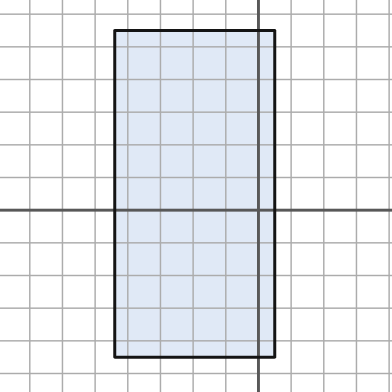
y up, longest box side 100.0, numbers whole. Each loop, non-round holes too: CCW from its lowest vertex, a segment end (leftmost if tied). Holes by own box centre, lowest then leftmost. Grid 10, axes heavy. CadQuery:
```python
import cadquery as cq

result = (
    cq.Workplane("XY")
    .moveTo(-44.0, -45.0)
    .lineTo(5.0, -45.0)
    .lineTo(5.0, 55.0)
    .lineTo(-44.0, 55.0)
    .close()
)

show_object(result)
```